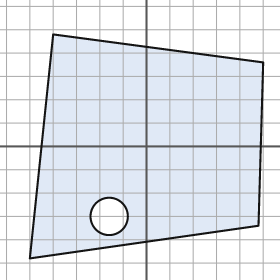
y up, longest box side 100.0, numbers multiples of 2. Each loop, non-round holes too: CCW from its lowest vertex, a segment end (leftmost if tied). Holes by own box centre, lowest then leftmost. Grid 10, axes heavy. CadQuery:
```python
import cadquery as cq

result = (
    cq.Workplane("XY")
    .moveTo(-50.0, -48.0)
    .lineTo(48.0, -34.0)
    .lineTo(50.0, 36.0)
    .lineTo(-40.0, 48.0)
    .close()
    .moveTo(-16.0, -30.0)
    .circle(8.0)
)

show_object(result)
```